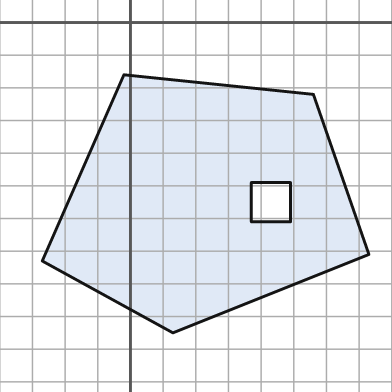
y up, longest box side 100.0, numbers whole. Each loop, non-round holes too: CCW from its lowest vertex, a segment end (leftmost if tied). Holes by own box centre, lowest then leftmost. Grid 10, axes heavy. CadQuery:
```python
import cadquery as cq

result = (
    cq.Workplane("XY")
    .moveTo(13.0, -95.0)
    .lineTo(73.0, -71.0)
    .lineTo(56.0, -22.0)
    .lineTo(-2.0, -16.0)
    .lineTo(-27.0, -73.0)
    .close()
    .moveTo(37.0, -61.0)
    .lineTo(49.0, -61.0)
    .lineTo(49.0, -49.0)
    .lineTo(37.0, -49.0)
    .close()
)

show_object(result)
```